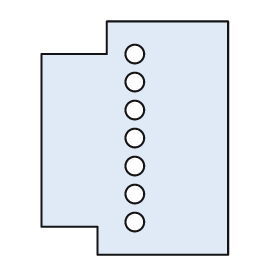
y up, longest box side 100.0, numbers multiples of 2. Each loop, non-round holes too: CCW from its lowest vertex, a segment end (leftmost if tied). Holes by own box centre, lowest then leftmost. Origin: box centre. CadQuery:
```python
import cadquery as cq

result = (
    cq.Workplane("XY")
    .moveTo(-16.0, -50.0)
    .lineTo(40.0, -50.0)
    .lineTo(40.0, 50.0)
    .lineTo(-12.0, 50.0)
    .lineTo(-12.0, 36.0)
    .lineTo(-40.0, 36.0)
    .lineTo(-40.0, -38.0)
    .lineTo(-16.0, -38.0)
    .close()
    .moveTo(0.0, -36.0)
    .circle(4.0)
    .moveTo(0.0, -24.0)
    .circle(4.0)
    .moveTo(0.0, -12.0)
    .circle(4.0)
    .moveTo(0.0, 0.0)
    .circle(4.0)
    .moveTo(0.0, 12.0)
    .circle(4.0)
    .moveTo(0.0, 24.0)
    .circle(4.0)
    .moveTo(0.0, 36.0)
    .circle(4.0)
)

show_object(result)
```